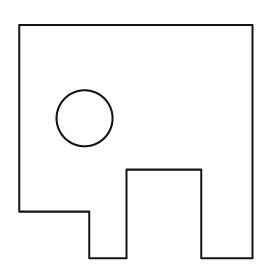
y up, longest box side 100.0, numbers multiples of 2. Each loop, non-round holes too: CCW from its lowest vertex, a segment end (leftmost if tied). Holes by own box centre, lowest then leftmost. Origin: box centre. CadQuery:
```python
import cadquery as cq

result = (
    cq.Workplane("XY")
    .moveTo(-20.0, -50.0)
    .lineTo(-4.0, -50.0)
    .lineTo(-4.0, -12.0)
    .lineTo(28.0, -12.0)
    .lineTo(28.0, -50.0)
    .lineTo(50.0, -50.0)
    .lineTo(50.0, 50.0)
    .lineTo(-50.0, 50.0)
    .lineTo(-50.0, -30.0)
    .lineTo(-20.0, -30.0)
    .close()
    .moveTo(-22.0, 10.0)
    .circle(12.0)
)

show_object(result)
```